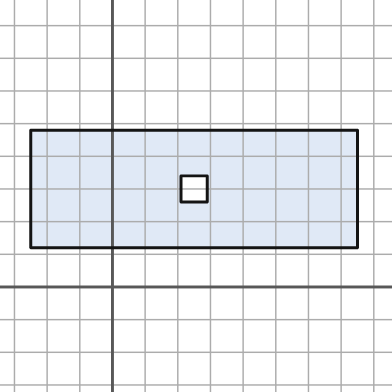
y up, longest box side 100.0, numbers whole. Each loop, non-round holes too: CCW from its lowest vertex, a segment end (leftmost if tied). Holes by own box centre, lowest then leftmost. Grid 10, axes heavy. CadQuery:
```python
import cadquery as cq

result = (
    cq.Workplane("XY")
    .moveTo(-25.0, 12.0)
    .lineTo(75.0, 12.0)
    .lineTo(75.0, 48.0)
    .lineTo(-25.0, 48.0)
    .close()
    .moveTo(21.0, 26.0)
    .lineTo(29.0, 26.0)
    .lineTo(29.0, 34.0)
    .lineTo(21.0, 34.0)
    .close()
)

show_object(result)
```